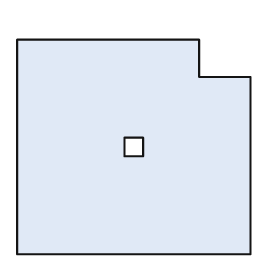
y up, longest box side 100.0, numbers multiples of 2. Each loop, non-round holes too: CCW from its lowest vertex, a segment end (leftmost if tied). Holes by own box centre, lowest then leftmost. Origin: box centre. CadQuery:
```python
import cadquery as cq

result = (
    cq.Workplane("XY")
    .moveTo(-50.0, -46.0)
    .lineTo(50.0, -46.0)
    .lineTo(50.0, 30.0)
    .lineTo(28.0, 30.0)
    .lineTo(28.0, 46.0)
    .lineTo(-50.0, 46.0)
    .close()
    .moveTo(-4.0, -4.0)
    .lineTo(4.0, -4.0)
    .lineTo(4.0, 4.0)
    .lineTo(-4.0, 4.0)
    .close()
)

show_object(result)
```